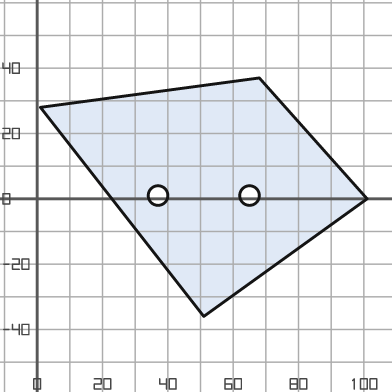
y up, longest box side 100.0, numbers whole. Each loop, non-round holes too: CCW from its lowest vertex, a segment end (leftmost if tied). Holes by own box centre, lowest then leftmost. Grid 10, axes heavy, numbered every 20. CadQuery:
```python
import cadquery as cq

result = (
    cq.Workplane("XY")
    .moveTo(51.0, -36.0)
    .lineTo(101.0, 0.0)
    .lineTo(68.0, 37.0)
    .lineTo(1.0, 28.0)
    .close()
    .moveTo(37.0, 1.0)
    .circle(3.0)
    .moveTo(65.0, 1.0)
    .circle(3.0)
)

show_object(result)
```